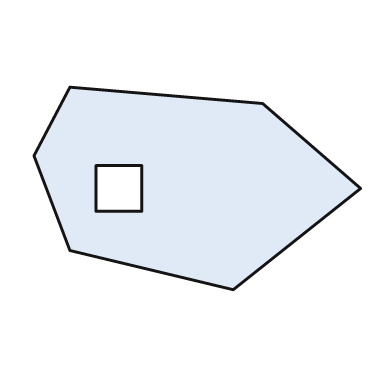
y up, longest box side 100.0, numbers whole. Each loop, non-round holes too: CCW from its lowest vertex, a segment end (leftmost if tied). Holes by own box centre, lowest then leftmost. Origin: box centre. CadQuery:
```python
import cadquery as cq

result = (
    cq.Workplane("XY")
    .moveTo(11.0, -31.0)
    .lineTo(50.0, 0.0)
    .lineTo(20.0, 26.0)
    .lineTo(-39.0, 31.0)
    .lineTo(-50.0, 10.0)
    .lineTo(-39.0, -19.0)
    .close()
    .moveTo(-31.0, -7.0)
    .lineTo(-17.0, -7.0)
    .lineTo(-17.0, 7.0)
    .lineTo(-31.0, 7.0)
    .close()
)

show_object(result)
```